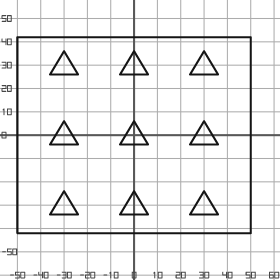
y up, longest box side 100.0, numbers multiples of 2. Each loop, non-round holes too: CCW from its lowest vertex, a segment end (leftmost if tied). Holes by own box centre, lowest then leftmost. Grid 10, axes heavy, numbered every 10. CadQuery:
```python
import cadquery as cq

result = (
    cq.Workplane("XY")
    .moveTo(-50.0, -42.0)
    .lineTo(50.0, -42.0)
    .lineTo(50.0, 42.0)
    .lineTo(-50.0, 42.0)
    .close()
    .moveTo(-36.0, -34.0)
    .lineTo(-24.0, -34.0)
    .lineTo(-30.0, -24.0)
    .close()
    .moveTo(-6.0, -34.0)
    .lineTo(6.0, -34.0)
    .lineTo(0.0, -24.0)
    .close()
    .moveTo(24.0, -34.0)
    .lineTo(36.0, -34.0)
    .lineTo(30.0, -24.0)
    .close()
    .moveTo(-36.0, -4.0)
    .lineTo(-24.0, -4.0)
    .lineTo(-30.0, 6.0)
    .close()
    .moveTo(-6.0, -4.0)
    .lineTo(6.0, -4.0)
    .lineTo(0.0, 6.0)
    .close()
    .moveTo(24.0, -4.0)
    .lineTo(36.0, -4.0)
    .lineTo(30.0, 6.0)
    .close()
    .moveTo(-36.0, 26.0)
    .lineTo(-24.0, 26.0)
    .lineTo(-30.0, 36.0)
    .close()
    .moveTo(-6.0, 26.0)
    .lineTo(6.0, 26.0)
    .lineTo(0.0, 36.0)
    .close()
    .moveTo(24.0, 26.0)
    .lineTo(36.0, 26.0)
    .lineTo(30.0, 36.0)
    .close()
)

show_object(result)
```